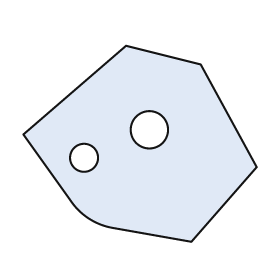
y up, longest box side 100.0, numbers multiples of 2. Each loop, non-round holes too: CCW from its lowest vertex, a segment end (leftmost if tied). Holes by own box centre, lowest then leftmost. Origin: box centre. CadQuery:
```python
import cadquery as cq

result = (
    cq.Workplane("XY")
    .moveTo(22.0, -42.0)
    .lineTo(50.0, -10.0)
    .lineTo(26.0, 34.0)
    .lineTo(-6.0, 42.0)
    .lineTo(-50.0, 4.0)
    .lineTo(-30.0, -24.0)
    .threePointArc((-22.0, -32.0), (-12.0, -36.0))
    .close()
    .moveTo(-24.0, -6.0)
    .circle(6.0)
    .moveTo(4.0, 6.0)
    .circle(8.0)
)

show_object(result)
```